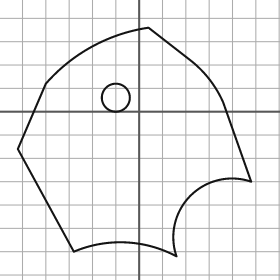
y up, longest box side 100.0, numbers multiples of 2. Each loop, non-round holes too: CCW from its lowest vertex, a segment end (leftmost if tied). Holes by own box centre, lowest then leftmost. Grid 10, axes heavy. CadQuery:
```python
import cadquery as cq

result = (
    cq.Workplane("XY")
    .moveTo(16.0, -62.0)
    .threePointArc((22.0, -36.0), (48.0, -30.0))
    .lineTo(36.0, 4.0)
    .threePointArc((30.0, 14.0), (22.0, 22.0))
    .lineTo(4.0, 36.0)
    .threePointArc((-20.0, 28.0), (-40.0, 12.0))
    .lineTo(-52.0, -16.0)
    .lineTo(-28.0, -60.0)
    .threePointArc((-6.0, -56.0), (16.0, -62.0))
    .close()
    .moveTo(-10.0, 6.0)
    .circle(6.0)
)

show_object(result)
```